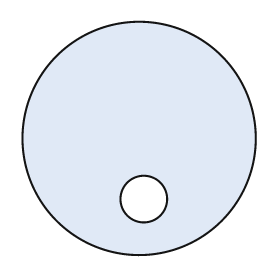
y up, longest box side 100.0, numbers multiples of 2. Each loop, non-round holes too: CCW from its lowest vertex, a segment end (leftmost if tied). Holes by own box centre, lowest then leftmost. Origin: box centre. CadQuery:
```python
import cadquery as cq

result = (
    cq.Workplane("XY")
    .moveTo(0.0, 0.0)
    .circle(50.0)
    .moveTo(2.0, -26.0)
    .circle(10.0)
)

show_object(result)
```